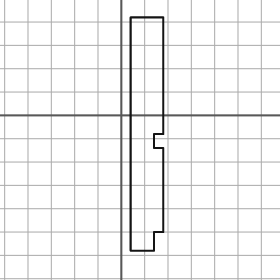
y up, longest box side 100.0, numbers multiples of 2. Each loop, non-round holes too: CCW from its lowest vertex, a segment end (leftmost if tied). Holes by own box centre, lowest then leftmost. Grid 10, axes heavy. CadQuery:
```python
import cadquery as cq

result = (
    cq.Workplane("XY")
    .moveTo(4.0, -58.0)
    .lineTo(14.0, -58.0)
    .lineTo(14.0, -50.0)
    .lineTo(18.0, -50.0)
    .lineTo(18.0, -14.0)
    .lineTo(14.0, -14.0)
    .lineTo(14.0, -8.0)
    .lineTo(18.0, -8.0)
    .lineTo(18.0, 42.0)
    .lineTo(4.0, 42.0)
    .close()
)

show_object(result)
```